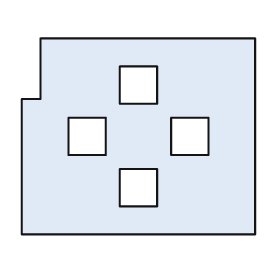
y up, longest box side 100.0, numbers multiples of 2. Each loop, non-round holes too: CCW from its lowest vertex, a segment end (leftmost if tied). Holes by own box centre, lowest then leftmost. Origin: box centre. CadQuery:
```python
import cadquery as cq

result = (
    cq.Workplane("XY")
    .moveTo(-50.0, -42.0)
    .lineTo(50.0, -42.0)
    .lineTo(50.0, 42.0)
    .lineTo(-42.0, 42.0)
    .lineTo(-42.0, 16.0)
    .lineTo(-50.0, 16.0)
    .close()
    .moveTo(-8.0, -30.0)
    .lineTo(8.0, -30.0)
    .lineTo(8.0, -14.0)
    .lineTo(-8.0, -14.0)
    .close()
    .moveTo(-30.0, -8.0)
    .lineTo(-14.0, -8.0)
    .lineTo(-14.0, 8.0)
    .lineTo(-30.0, 8.0)
    .close()
    .moveTo(14.0, -8.0)
    .lineTo(30.0, -8.0)
    .lineTo(30.0, 8.0)
    .lineTo(14.0, 8.0)
    .close()
    .moveTo(-8.0, 14.0)
    .lineTo(8.0, 14.0)
    .lineTo(8.0, 30.0)
    .lineTo(-8.0, 30.0)
    .close()
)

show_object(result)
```